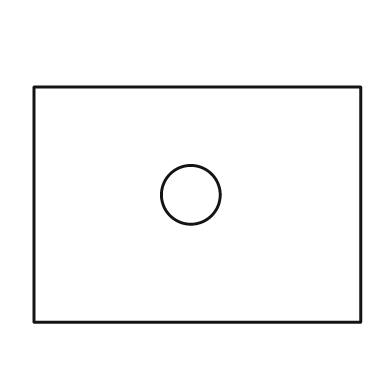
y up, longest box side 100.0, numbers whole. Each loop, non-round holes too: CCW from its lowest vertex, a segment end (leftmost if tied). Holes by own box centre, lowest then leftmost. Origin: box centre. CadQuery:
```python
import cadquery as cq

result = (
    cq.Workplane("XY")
    .moveTo(-50.0, -36.0)
    .lineTo(50.0, -36.0)
    .lineTo(50.0, 36.0)
    .lineTo(-50.0, 36.0)
    .close()
    .moveTo(-2.0, 3.0)
    .circle(9.0)
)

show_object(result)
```